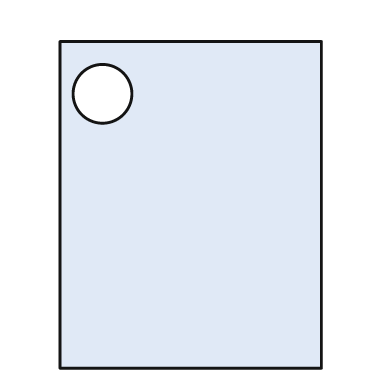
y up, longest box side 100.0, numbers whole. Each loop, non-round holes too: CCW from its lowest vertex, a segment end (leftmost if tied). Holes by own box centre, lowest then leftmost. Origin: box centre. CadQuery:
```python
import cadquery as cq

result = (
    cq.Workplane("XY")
    .moveTo(-40.0, -50.0)
    .lineTo(40.0, -50.0)
    .lineTo(40.0, 50.0)
    .lineTo(-40.0, 50.0)
    .close()
    .moveTo(-27.0, 34.0)
    .circle(9.0)
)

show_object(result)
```